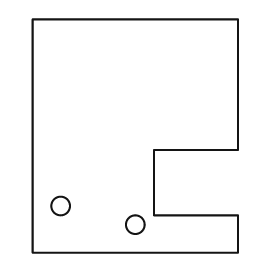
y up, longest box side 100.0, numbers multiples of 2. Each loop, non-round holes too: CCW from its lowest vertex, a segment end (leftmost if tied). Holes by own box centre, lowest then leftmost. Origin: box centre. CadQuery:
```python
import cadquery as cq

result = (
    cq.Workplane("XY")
    .moveTo(-44.0, -50.0)
    .lineTo(44.0, -50.0)
    .lineTo(44.0, -34.0)
    .lineTo(8.0, -34.0)
    .lineTo(8.0, -6.0)
    .lineTo(44.0, -6.0)
    .lineTo(44.0, 50.0)
    .lineTo(-44.0, 50.0)
    .close()
    .moveTo(0.0, -38.0)
    .circle(4.0)
    .moveTo(-32.0, -30.0)
    .circle(4.0)
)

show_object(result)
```